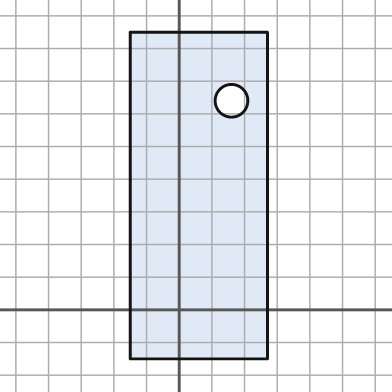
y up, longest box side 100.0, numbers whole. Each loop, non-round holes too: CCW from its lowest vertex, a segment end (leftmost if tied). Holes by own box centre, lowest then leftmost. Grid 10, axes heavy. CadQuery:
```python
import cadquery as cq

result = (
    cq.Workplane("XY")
    .moveTo(-15.0, -15.0)
    .lineTo(27.0, -15.0)
    .lineTo(27.0, 85.0)
    .lineTo(-15.0, 85.0)
    .close()
    .moveTo(16.0, 64.0)
    .circle(5.0)
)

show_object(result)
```